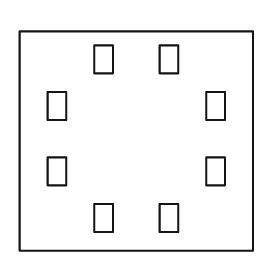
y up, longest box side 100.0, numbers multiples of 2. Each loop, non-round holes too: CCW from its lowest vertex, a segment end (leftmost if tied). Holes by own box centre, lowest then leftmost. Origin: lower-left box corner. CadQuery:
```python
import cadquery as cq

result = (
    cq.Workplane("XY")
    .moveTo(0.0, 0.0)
    .lineTo(100.0, 0.0)
    .lineTo(100.0, 94.0)
    .lineTo(0.0, 94.0)
    .close()
    .moveTo(32.0, 8.0)
    .lineTo(40.0, 8.0)
    .lineTo(40.0, 20.0)
    .lineTo(32.0, 20.0)
    .close()
    .moveTo(60.0, 8.0)
    .lineTo(68.0, 8.0)
    .lineTo(68.0, 20.0)
    .lineTo(60.0, 20.0)
    .close()
    .moveTo(12.0, 28.0)
    .lineTo(20.0, 28.0)
    .lineTo(20.0, 40.0)
    .lineTo(12.0, 40.0)
    .close()
    .moveTo(80.0, 28.0)
    .lineTo(88.0, 28.0)
    .lineTo(88.0, 40.0)
    .lineTo(80.0, 40.0)
    .close()
    .moveTo(12.0, 56.0)
    .lineTo(20.0, 56.0)
    .lineTo(20.0, 68.0)
    .lineTo(12.0, 68.0)
    .close()
    .moveTo(80.0, 56.0)
    .lineTo(88.0, 56.0)
    .lineTo(88.0, 68.0)
    .lineTo(80.0, 68.0)
    .close()
    .moveTo(32.0, 76.0)
    .lineTo(40.0, 76.0)
    .lineTo(40.0, 88.0)
    .lineTo(32.0, 88.0)
    .close()
    .moveTo(60.0, 76.0)
    .lineTo(68.0, 76.0)
    .lineTo(68.0, 88.0)
    .lineTo(60.0, 88.0)
    .close()
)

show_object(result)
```